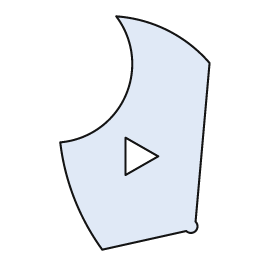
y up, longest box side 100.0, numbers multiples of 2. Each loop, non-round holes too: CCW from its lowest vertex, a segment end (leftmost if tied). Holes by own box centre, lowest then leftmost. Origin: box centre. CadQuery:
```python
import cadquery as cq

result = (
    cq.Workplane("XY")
    .moveTo(-14.0, -50.0)
    .lineTo(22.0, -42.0)
    .threePointArc((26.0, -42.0), (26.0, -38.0))
    .lineTo(32.0, 30.0)
    .threePointArc((14.0, 44.0), (-8.0, 50.0))
    .threePointArc((-4.0, 16.0), (-32.0, -4.0))
    .threePointArc((-26.0, -28.0), (-14.0, -50.0))
    .close()
    .moveTo(-4.0, -18.0)
    .lineTo(10.0, -10.0)
    .lineTo(-4.0, -2.0)
    .close()
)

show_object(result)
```